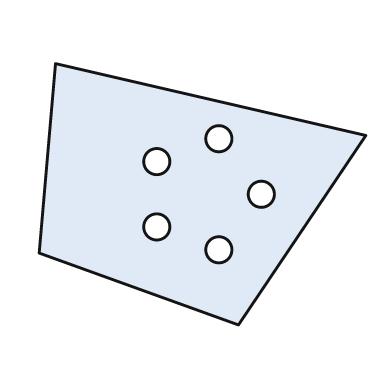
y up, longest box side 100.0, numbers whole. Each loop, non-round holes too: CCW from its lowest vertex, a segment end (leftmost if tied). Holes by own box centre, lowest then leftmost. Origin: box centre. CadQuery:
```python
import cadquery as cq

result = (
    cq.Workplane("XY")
    .moveTo(11.0, -40.0)
    .lineTo(50.0, 18.0)
    .lineTo(-45.0, 40.0)
    .lineTo(-50.0, -18.0)
    .close()
    .moveTo(5.0, -17.0)
    .circle(4.0)
    .moveTo(-14.0, -10.0)
    .circle(4.0)
    .moveTo(18.0, 0.0)
    .circle(4.0)
    .moveTo(-14.0, 10.0)
    .circle(4.0)
    .moveTo(5.0, 17.0)
    .circle(4.0)
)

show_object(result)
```